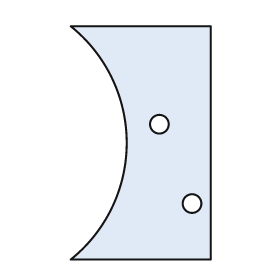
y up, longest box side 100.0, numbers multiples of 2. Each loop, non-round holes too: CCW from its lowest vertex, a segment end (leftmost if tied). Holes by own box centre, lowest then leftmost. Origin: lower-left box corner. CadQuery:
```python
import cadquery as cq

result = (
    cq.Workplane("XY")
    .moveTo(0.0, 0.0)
    .lineTo(60.0, 0.0)
    .lineTo(60.0, 100.0)
    .lineTo(0.0, 100.0)
    .threePointArc((24.0, 50.0), (0.0, 0.0))
    .close()
    .moveTo(52.0, 24.0)
    .circle(4.0)
    .moveTo(38.0, 58.0)
    .circle(4.0)
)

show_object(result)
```